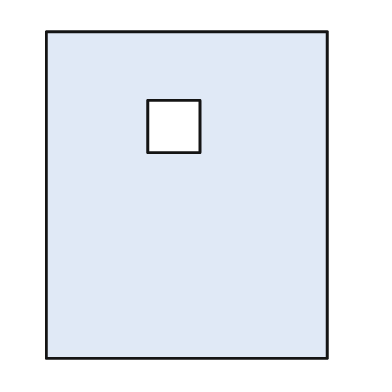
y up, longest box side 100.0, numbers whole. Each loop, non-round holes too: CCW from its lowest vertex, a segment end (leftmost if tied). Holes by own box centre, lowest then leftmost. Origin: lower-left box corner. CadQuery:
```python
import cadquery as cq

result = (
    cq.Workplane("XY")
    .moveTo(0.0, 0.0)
    .lineTo(86.0, 0.0)
    .lineTo(86.0, 100.0)
    .lineTo(0.0, 100.0)
    .close()
    .moveTo(31.0, 63.0)
    .lineTo(47.0, 63.0)
    .lineTo(47.0, 79.0)
    .lineTo(31.0, 79.0)
    .close()
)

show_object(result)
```